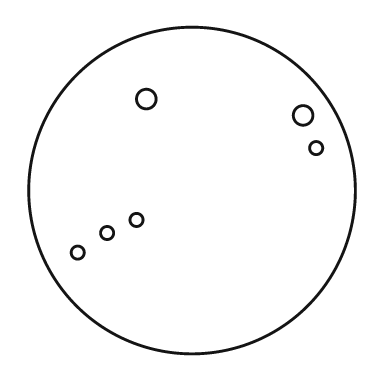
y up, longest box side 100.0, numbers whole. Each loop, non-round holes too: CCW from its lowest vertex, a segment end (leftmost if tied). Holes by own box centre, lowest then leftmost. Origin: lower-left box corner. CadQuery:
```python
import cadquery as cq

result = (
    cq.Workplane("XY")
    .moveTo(50.0, 50.0)
    .circle(50.0)
    .moveTo(15.0, 31.0)
    .circle(2.0)
    .moveTo(24.0, 37.0)
    .circle(2.0)
    .moveTo(33.0, 41.0)
    .circle(2.0)
    .moveTo(88.0, 63.0)
    .circle(2.0)
    .moveTo(84.0, 73.0)
    .circle(3.0)
    .moveTo(36.0, 78.0)
    .circle(3.0)
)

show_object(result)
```